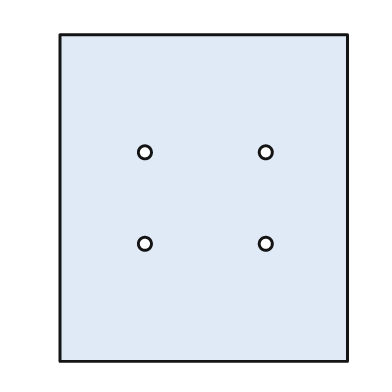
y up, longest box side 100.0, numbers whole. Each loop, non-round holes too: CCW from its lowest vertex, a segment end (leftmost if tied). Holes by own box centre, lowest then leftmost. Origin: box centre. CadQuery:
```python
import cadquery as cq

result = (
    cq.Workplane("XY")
    .moveTo(-44.0, -50.0)
    .lineTo(44.0, -50.0)
    .lineTo(44.0, 50.0)
    .lineTo(-44.0, 50.0)
    .close()
    .moveTo(-18.0, -14.0)
    .circle(2.0)
    .moveTo(19.0, -14.0)
    .circle(2.0)
    .moveTo(-18.0, 14.0)
    .circle(2.0)
    .moveTo(19.0, 14.0)
    .circle(2.0)
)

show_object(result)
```